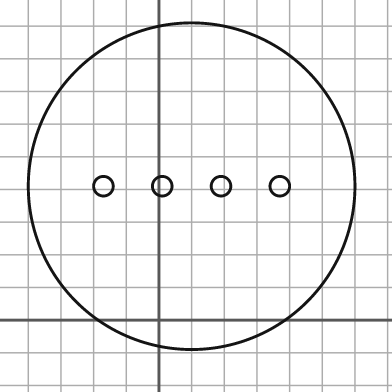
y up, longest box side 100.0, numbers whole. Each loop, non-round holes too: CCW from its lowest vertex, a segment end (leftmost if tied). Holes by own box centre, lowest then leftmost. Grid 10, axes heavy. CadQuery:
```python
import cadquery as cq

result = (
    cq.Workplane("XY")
    .moveTo(10.0, 41.0)
    .circle(50.0)
    .moveTo(-17.0, 41.0)
    .circle(3.0)
    .moveTo(1.0, 41.0)
    .circle(3.0)
    .moveTo(19.0, 41.0)
    .circle(3.0)
    .moveTo(37.0, 41.0)
    .circle(3.0)
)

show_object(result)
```